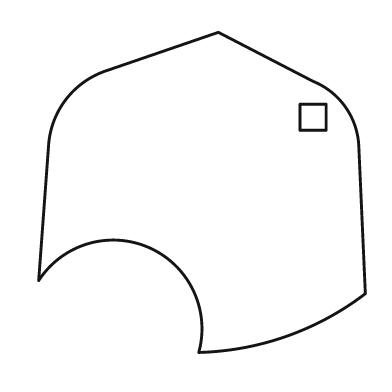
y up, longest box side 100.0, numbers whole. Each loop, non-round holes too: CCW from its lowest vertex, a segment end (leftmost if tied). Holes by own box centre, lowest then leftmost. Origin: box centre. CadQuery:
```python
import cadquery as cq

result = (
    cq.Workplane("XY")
    .moveTo(-1.0, -49.0)
    .threePointArc((26.0, -44.0), (50.0, -31.0))
    .lineTo(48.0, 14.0)
    .threePointArc((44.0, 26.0), (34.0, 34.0))
    .lineTo(5.0, 49.0)
    .lineTo(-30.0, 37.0)
    .threePointArc((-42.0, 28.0), (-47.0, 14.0))
    .lineTo(-50.0, -27.0)
    .threePointArc((-16.0, -17.0), (-1.0, -49.0))
    .close()
    .moveTo(30.0, 19.0)
    .lineTo(38.0, 19.0)
    .lineTo(38.0, 27.0)
    .lineTo(30.0, 27.0)
    .close()
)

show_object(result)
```